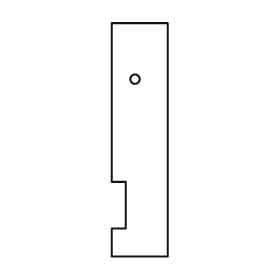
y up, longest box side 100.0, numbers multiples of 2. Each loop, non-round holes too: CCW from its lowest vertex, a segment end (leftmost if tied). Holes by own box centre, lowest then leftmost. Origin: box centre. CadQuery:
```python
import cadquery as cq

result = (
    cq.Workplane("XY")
    .moveTo(-12.0, -50.0)
    .lineTo(12.0, -50.0)
    .lineTo(12.0, 50.0)
    .lineTo(-12.0, 50.0)
    .lineTo(-12.0, -18.0)
    .lineTo(-6.0, -18.0)
    .lineTo(-6.0, -38.0)
    .lineTo(-12.0, -38.0)
    .close()
    .moveTo(-2.0, 26.0)
    .circle(2.0)
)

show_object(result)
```